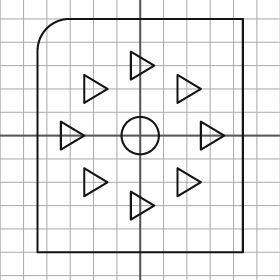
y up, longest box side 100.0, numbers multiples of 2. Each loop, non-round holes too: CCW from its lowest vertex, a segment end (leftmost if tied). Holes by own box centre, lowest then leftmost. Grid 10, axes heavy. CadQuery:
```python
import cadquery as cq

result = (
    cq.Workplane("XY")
    .moveTo(-44.0, -50.0)
    .lineTo(44.0, -50.0)
    .lineTo(44.0, 50.0)
    .lineTo(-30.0, 50.0)
    .threePointArc((-40.0, 46.0), (-44.0, 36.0))
    .close()
    .moveTo(-4.0, -36.0)
    .lineTo(6.0, -30.0)
    .lineTo(-4.0, -24.0)
    .close()
    .moveTo(-24.0, -26.0)
    .lineTo(-14.0, -20.0)
    .lineTo(-24.0, -14.0)
    .close()
    .moveTo(16.0, -26.0)
    .lineTo(26.0, -20.0)
    .lineTo(16.0, -14.0)
    .close()
    .moveTo(-34.0, -6.0)
    .lineTo(-24.0, 0.0)
    .lineTo(-34.0, 6.0)
    .close()
    .moveTo(0.0, 0.0)
    .circle(8.0)
    .moveTo(26.0, -6.0)
    .lineTo(36.0, 0.0)
    .lineTo(26.0, 6.0)
    .close()
    .moveTo(-24.0, 14.0)
    .lineTo(-14.0, 20.0)
    .lineTo(-24.0, 26.0)
    .close()
    .moveTo(16.0, 14.0)
    .lineTo(26.0, 20.0)
    .lineTo(16.0, 26.0)
    .close()
    .moveTo(-4.0, 24.0)
    .lineTo(6.0, 30.0)
    .lineTo(-4.0, 36.0)
    .close()
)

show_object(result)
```